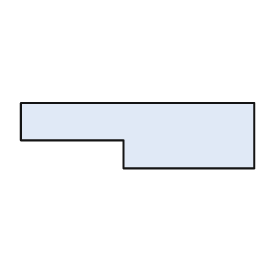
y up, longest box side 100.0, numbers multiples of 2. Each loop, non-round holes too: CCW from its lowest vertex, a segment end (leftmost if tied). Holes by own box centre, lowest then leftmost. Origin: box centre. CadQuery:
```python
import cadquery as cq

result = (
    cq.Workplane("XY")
    .moveTo(-6.0, -14.0)
    .lineTo(50.0, -14.0)
    .lineTo(50.0, 14.0)
    .lineTo(-50.0, 14.0)
    .lineTo(-50.0, -2.0)
    .lineTo(-6.0, -2.0)
    .close()
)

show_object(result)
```